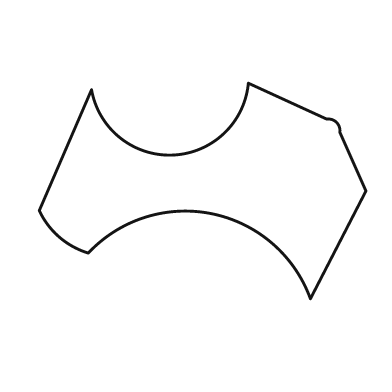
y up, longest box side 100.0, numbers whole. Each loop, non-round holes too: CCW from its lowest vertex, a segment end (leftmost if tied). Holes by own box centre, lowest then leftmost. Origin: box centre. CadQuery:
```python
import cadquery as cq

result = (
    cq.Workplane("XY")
    .moveTo(33.0, -33.0)
    .lineTo(50.0, 0.0)
    .lineTo(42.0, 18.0)
    .threePointArc((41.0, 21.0), (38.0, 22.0))
    .lineTo(14.0, 33.0)
    .threePointArc((-9.0, 11.0), (-34.0, 31.0))
    .lineTo(-50.0, -6.0)
    .threePointArc((-44.0, -14.0), (-35.0, -19.0))
    .threePointArc((3.0, -7.0), (33.0, -33.0))
    .close()
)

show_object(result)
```